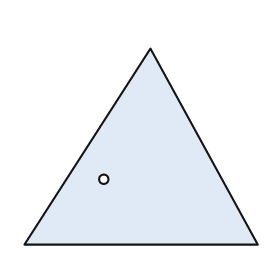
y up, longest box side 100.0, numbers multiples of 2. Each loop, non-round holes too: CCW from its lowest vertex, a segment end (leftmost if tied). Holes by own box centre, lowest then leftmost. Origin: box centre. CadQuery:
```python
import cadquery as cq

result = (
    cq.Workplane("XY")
    .moveTo(-50.0, -42.0)
    .lineTo(50.0, -42.0)
    .lineTo(4.0, 42.0)
    .close()
    .moveTo(-16.0, -14.0)
    .circle(2.0)
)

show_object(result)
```